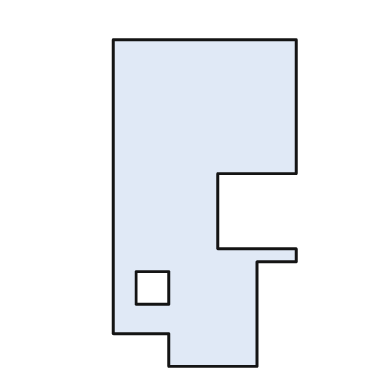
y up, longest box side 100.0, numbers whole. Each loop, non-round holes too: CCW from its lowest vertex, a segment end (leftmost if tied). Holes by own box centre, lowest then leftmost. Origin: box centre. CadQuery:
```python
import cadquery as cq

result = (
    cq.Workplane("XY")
    .moveTo(-11.0, -50.0)
    .lineTo(16.0, -50.0)
    .lineTo(16.0, -18.0)
    .lineTo(28.0, -18.0)
    .lineTo(28.0, -14.0)
    .lineTo(4.0, -14.0)
    .lineTo(4.0, 9.0)
    .lineTo(28.0, 9.0)
    .lineTo(28.0, 50.0)
    .lineTo(-28.0, 50.0)
    .lineTo(-28.0, -40.0)
    .lineTo(-11.0, -40.0)
    .close()
    .moveTo(-21.0, -31.0)
    .lineTo(-11.0, -31.0)
    .lineTo(-11.0, -21.0)
    .lineTo(-21.0, -21.0)
    .close()
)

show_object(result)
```